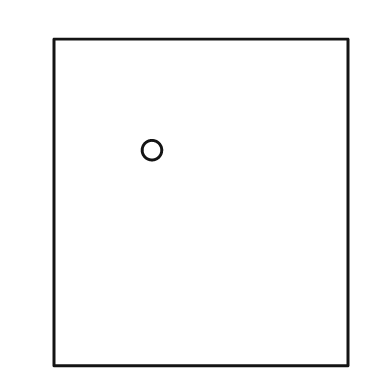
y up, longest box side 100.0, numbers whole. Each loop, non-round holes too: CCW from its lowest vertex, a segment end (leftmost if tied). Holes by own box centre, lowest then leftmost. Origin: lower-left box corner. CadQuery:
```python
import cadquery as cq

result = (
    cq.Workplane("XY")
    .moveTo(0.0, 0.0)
    .lineTo(90.0, 0.0)
    .lineTo(90.0, 100.0)
    .lineTo(0.0, 100.0)
    .close()
    .moveTo(30.0, 66.0)
    .circle(3.0)
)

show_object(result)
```